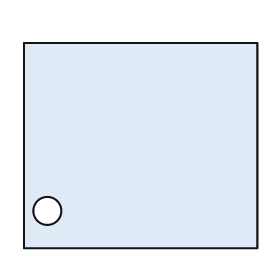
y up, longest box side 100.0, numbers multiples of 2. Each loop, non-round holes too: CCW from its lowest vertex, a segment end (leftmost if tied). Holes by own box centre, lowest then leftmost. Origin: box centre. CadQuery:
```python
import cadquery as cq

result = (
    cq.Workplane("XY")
    .moveTo(-50.0, -44.0)
    .lineTo(50.0, -44.0)
    .lineTo(50.0, 44.0)
    .lineTo(-50.0, 44.0)
    .close()
    .moveTo(-40.0, -28.0)
    .circle(6.0)
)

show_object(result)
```